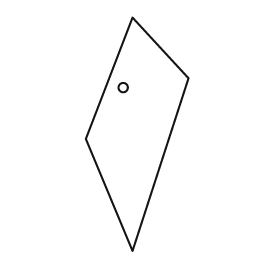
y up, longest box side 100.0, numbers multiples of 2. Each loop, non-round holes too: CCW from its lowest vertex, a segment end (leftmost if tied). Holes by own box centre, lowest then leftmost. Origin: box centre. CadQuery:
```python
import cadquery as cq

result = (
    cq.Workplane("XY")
    .moveTo(-2.0, -50.0)
    .lineTo(22.0, 24.0)
    .lineTo(-2.0, 50.0)
    .lineTo(-22.0, -2.0)
    .close()
    .moveTo(-6.0, 20.0)
    .circle(2.0)
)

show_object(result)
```